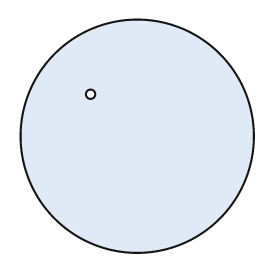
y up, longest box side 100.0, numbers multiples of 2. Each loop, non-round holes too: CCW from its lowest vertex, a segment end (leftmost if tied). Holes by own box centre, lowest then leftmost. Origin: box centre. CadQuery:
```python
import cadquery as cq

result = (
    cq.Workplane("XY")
    .moveTo(0.0, 0.0)
    .circle(50.0)
    .moveTo(-20.0, 18.0)
    .circle(2.0)
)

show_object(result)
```